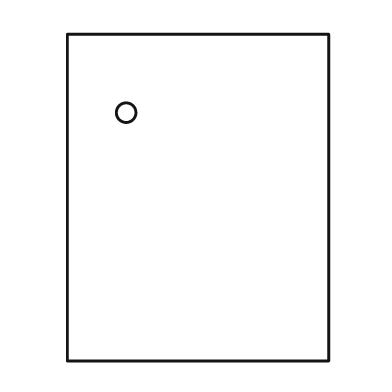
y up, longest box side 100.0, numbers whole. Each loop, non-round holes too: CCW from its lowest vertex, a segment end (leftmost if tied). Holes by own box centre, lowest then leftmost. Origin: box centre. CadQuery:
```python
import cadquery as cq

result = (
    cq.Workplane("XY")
    .moveTo(-40.0, -50.0)
    .lineTo(40.0, -50.0)
    .lineTo(40.0, 50.0)
    .lineTo(-40.0, 50.0)
    .close()
    .moveTo(-22.0, 26.0)
    .circle(3.0)
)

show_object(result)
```